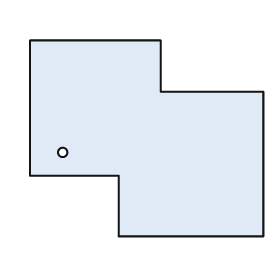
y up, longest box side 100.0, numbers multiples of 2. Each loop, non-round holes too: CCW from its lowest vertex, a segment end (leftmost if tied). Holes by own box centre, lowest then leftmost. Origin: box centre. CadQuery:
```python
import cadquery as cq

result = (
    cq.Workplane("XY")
    .moveTo(-12.0, -42.0)
    .lineTo(50.0, -42.0)
    .lineTo(50.0, 20.0)
    .lineTo(6.0, 20.0)
    .lineTo(6.0, 42.0)
    .lineTo(-50.0, 42.0)
    .lineTo(-50.0, -16.0)
    .lineTo(-12.0, -16.0)
    .close()
    .moveTo(-36.0, -6.0)
    .circle(2.0)
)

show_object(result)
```